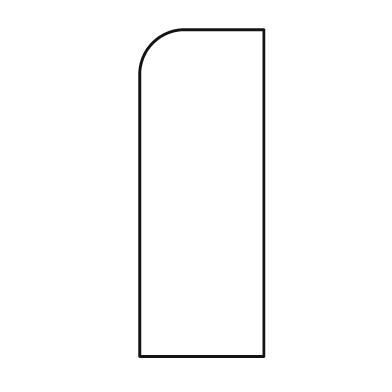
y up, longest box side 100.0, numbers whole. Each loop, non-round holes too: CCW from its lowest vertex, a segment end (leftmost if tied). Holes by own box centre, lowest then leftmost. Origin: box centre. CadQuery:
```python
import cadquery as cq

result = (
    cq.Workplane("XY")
    .moveTo(-19.0, -50.0)
    .lineTo(19.0, -50.0)
    .lineTo(19.0, 50.0)
    .lineTo(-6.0, 50.0)
    .threePointArc((-15.0, 46.0), (-19.0, 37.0))
    .close()
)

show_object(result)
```